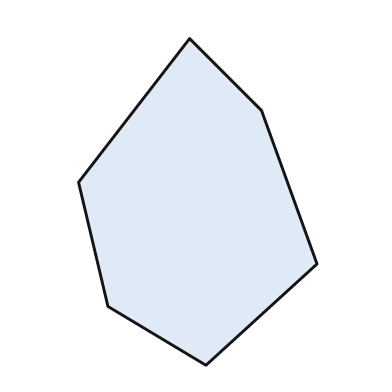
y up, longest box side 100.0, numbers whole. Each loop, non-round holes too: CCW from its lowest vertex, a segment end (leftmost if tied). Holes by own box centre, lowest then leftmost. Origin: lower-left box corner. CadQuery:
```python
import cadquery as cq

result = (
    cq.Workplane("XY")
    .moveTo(39.0, 0.0)
    .lineTo(73.0, 31.0)
    .lineTo(56.0, 78.0)
    .lineTo(34.0, 100.0)
    .lineTo(0.0, 56.0)
    .lineTo(9.0, 18.0)
    .close()
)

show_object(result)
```